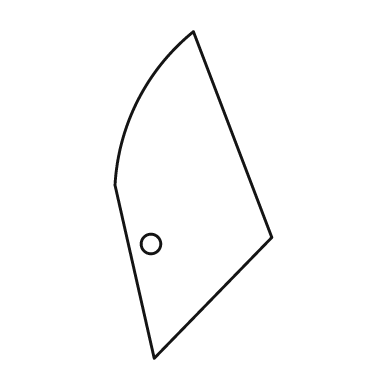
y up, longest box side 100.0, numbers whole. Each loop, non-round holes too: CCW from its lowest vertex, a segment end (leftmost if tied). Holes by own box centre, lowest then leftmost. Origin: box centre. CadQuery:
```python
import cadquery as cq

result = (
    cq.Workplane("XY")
    .moveTo(-12.0, -50.0)
    .lineTo(24.0, -13.0)
    .lineTo(0.0, 50.0)
    .threePointArc((-17.0, 29.0), (-24.0, 3.0))
    .close()
    .moveTo(-13.0, -15.0)
    .circle(3.0)
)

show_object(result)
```